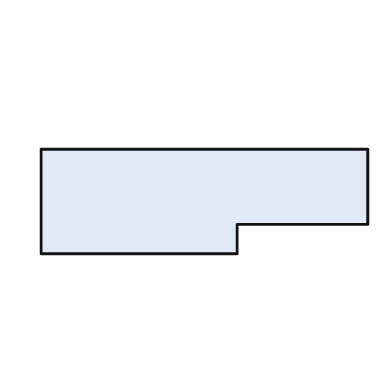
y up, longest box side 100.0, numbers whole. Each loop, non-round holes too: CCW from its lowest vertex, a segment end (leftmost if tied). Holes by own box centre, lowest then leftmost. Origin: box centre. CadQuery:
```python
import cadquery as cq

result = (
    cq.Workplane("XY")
    .moveTo(-50.0, -16.0)
    .lineTo(10.0, -16.0)
    .lineTo(10.0, -7.0)
    .lineTo(50.0, -7.0)
    .lineTo(50.0, 16.0)
    .lineTo(-50.0, 16.0)
    .close()
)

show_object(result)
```